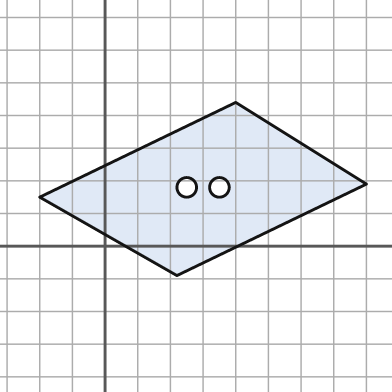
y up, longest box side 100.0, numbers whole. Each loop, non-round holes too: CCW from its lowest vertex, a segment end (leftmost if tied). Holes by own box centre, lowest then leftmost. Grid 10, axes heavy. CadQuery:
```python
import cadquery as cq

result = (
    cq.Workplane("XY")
    .moveTo(22.0, -9.0)
    .lineTo(80.0, 19.0)
    .lineTo(40.0, 44.0)
    .lineTo(-20.0, 15.0)
    .close()
    .moveTo(25.0, 18.0)
    .circle(3.0)
    .moveTo(35.0, 18.0)
    .circle(3.0)
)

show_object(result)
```